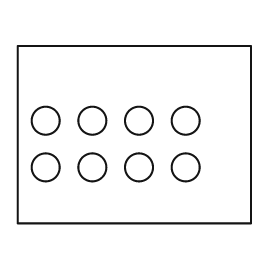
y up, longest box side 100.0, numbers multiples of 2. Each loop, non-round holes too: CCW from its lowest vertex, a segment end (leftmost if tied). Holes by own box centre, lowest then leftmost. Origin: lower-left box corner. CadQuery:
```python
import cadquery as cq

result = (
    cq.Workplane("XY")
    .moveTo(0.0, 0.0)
    .lineTo(100.0, 0.0)
    .lineTo(100.0, 76.0)
    .lineTo(0.0, 76.0)
    .close()
    .moveTo(12.0, 24.0)
    .circle(6.0)
    .moveTo(32.0, 24.0)
    .circle(6.0)
    .moveTo(52.0, 24.0)
    .circle(6.0)
    .moveTo(72.0, 24.0)
    .circle(6.0)
    .moveTo(12.0, 44.0)
    .circle(6.0)
    .moveTo(32.0, 44.0)
    .circle(6.0)
    .moveTo(52.0, 44.0)
    .circle(6.0)
    .moveTo(72.0, 44.0)
    .circle(6.0)
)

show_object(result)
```